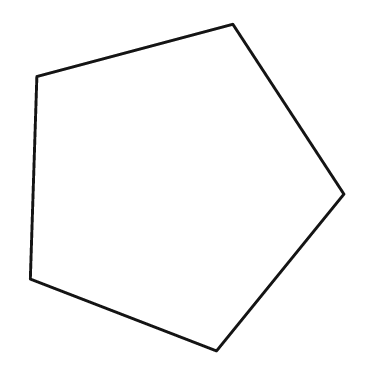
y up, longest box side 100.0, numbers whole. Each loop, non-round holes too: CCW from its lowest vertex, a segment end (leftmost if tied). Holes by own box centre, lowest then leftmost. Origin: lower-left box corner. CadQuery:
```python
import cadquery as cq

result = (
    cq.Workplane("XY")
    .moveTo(57.0, 0.0)
    .lineTo(96.0, 48.0)
    .lineTo(62.0, 100.0)
    .lineTo(2.0, 84.0)
    .lineTo(0.0, 22.0)
    .close()
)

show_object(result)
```